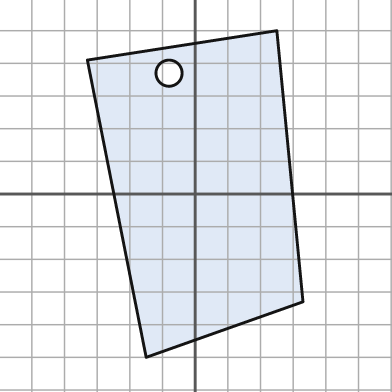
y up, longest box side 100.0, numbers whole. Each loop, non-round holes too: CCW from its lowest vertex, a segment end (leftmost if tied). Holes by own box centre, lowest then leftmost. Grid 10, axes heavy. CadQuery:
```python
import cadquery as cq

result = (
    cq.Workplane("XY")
    .moveTo(-15.0, -50.0)
    .lineTo(33.0, -33.0)
    .lineTo(25.0, 50.0)
    .lineTo(-33.0, 41.0)
    .close()
    .moveTo(-8.0, 37.0)
    .circle(4.0)
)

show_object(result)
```